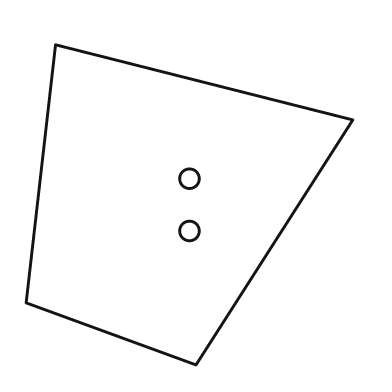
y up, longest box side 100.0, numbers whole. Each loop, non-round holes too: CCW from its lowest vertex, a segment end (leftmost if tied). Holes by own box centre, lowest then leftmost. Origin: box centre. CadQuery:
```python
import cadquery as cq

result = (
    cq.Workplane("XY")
    .moveTo(2.0, -49.0)
    .lineTo(50.0, 26.0)
    .lineTo(-41.0, 49.0)
    .lineTo(-50.0, -30.0)
    .close()
    .moveTo(0.0, -8.0)
    .circle(3.0)
    .moveTo(0.0, 8.0)
    .circle(3.0)
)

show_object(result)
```